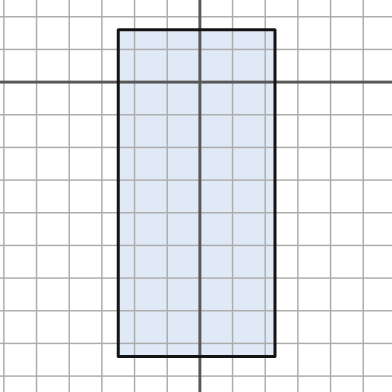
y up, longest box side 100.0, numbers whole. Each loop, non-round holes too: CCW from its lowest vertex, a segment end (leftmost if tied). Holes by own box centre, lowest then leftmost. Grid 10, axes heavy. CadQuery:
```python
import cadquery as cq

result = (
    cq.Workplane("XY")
    .moveTo(-25.0, -84.0)
    .lineTo(23.0, -84.0)
    .lineTo(23.0, 16.0)
    .lineTo(-25.0, 16.0)
    .close()
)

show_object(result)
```